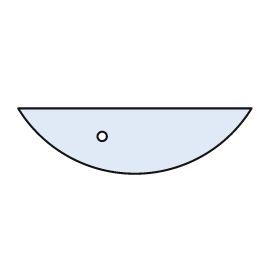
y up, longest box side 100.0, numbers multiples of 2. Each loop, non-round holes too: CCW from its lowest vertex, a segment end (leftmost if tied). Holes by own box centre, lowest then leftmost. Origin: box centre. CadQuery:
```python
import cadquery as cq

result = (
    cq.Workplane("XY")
    .moveTo(-50.0, 14.0)
    .threePointArc((0.0, -14.0), (50.0, 14.0))
    .close()
    .moveTo(-14.0, 2.0)
    .circle(2.0)
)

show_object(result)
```